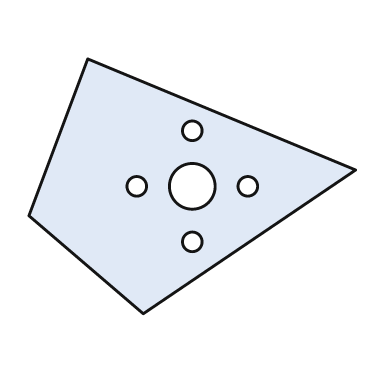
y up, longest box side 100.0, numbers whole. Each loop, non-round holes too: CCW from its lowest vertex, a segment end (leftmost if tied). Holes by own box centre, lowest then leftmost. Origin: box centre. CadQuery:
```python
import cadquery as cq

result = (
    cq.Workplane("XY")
    .moveTo(-15.0, -39.0)
    .lineTo(50.0, 5.0)
    .lineTo(-32.0, 39.0)
    .lineTo(-50.0, -9.0)
    .close()
    .moveTo(0.0, -17.0)
    .circle(3.0)
    .moveTo(-17.0, 0.0)
    .circle(3.0)
    .moveTo(0.0, 0.0)
    .circle(7.0)
    .moveTo(17.0, 0.0)
    .circle(3.0)
    .moveTo(0.0, 17.0)
    .circle(3.0)
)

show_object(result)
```